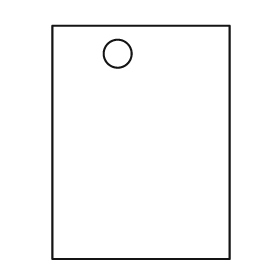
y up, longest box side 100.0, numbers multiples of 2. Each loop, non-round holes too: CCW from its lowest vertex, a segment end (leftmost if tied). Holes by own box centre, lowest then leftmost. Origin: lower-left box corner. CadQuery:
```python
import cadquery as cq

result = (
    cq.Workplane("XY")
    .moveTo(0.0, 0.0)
    .lineTo(76.0, 0.0)
    .lineTo(76.0, 100.0)
    .lineTo(0.0, 100.0)
    .close()
    .moveTo(28.0, 88.0)
    .circle(6.0)
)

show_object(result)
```